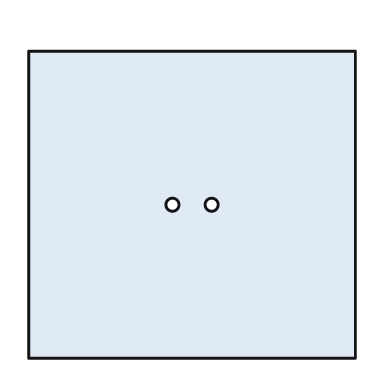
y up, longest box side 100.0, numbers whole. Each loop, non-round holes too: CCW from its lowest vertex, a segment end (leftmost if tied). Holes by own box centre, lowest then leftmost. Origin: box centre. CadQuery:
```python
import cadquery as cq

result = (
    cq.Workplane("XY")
    .moveTo(-50.0, -47.0)
    .lineTo(50.0, -47.0)
    .lineTo(50.0, 47.0)
    .lineTo(-50.0, 47.0)
    .close()
    .moveTo(-6.0, 0.0)
    .circle(2.0)
    .moveTo(6.0, 0.0)
    .circle(2.0)
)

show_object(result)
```